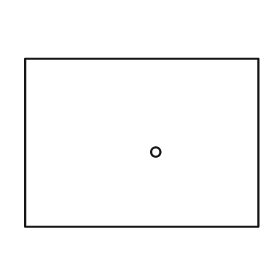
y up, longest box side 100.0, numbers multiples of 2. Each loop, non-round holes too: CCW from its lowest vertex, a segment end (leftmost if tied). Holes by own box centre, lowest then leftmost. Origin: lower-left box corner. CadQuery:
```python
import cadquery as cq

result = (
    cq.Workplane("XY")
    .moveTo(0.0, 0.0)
    .lineTo(100.0, 0.0)
    .lineTo(100.0, 72.0)
    .lineTo(0.0, 72.0)
    .close()
    .moveTo(56.0, 32.0)
    .circle(2.0)
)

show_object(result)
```